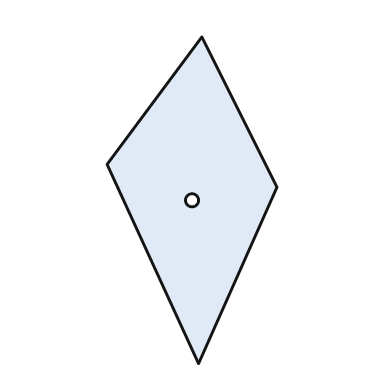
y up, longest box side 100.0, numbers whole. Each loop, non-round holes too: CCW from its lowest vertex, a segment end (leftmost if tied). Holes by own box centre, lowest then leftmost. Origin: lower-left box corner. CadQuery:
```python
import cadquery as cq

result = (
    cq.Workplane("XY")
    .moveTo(28.0, 0.0)
    .lineTo(52.0, 54.0)
    .lineTo(29.0, 100.0)
    .lineTo(0.0, 61.0)
    .close()
    .moveTo(26.0, 50.0)
    .circle(2.0)
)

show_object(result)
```